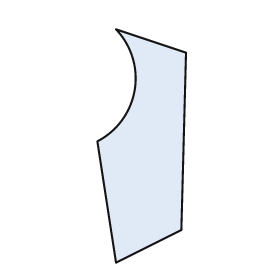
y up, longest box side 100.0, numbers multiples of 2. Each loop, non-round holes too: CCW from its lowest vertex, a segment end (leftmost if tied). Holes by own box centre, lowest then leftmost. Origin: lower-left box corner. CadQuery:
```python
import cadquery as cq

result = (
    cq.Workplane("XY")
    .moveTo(8.0, 0.0)
    .lineTo(36.0, 14.0)
    .lineTo(38.0, 90.0)
    .lineTo(8.0, 100.0)
    .threePointArc((16.0, 74.0), (0.0, 52.0))
    .close()
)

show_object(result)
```